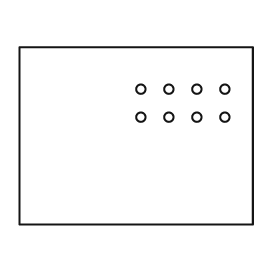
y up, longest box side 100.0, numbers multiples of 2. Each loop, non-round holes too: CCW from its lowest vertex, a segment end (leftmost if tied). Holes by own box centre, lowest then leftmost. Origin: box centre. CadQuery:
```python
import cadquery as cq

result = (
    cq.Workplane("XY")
    .moveTo(-50.0, -38.0)
    .lineTo(50.0, -38.0)
    .lineTo(50.0, 38.0)
    .lineTo(-50.0, 38.0)
    .close()
    .moveTo(2.0, 8.0)
    .circle(2.0)
    .moveTo(14.0, 8.0)
    .circle(2.0)
    .moveTo(26.0, 8.0)
    .circle(2.0)
    .moveTo(38.0, 8.0)
    .circle(2.0)
    .moveTo(2.0, 20.0)
    .circle(2.0)
    .moveTo(14.0, 20.0)
    .circle(2.0)
    .moveTo(26.0, 20.0)
    .circle(2.0)
    .moveTo(38.0, 20.0)
    .circle(2.0)
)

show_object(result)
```